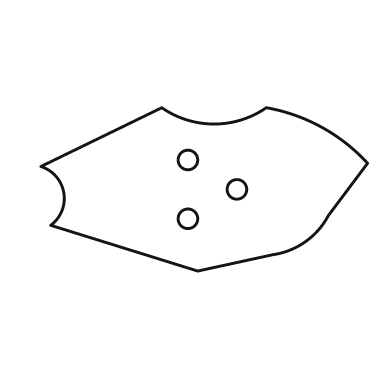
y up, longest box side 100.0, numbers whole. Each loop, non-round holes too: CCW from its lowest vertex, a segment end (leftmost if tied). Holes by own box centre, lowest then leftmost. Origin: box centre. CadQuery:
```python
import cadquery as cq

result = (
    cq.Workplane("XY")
    .moveTo(-2.0, -25.0)
    .lineTo(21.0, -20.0)
    .threePointArc((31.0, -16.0), (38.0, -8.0))
    .lineTo(50.0, 8.0)
    .threePointArc((36.0, 19.0), (19.0, 25.0))
    .threePointArc((3.0, 20.0), (-13.0, 25.0))
    .lineTo(-50.0, 7.0)
    .threePointArc((-43.0, -1.0), (-47.0, -11.0))
    .close()
    .moveTo(-5.0, -9.0)
    .circle(3.0)
    .moveTo(10.0, 0.0)
    .circle(3.0)
    .moveTo(-5.0, 9.0)
    .circle(3.0)
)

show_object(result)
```